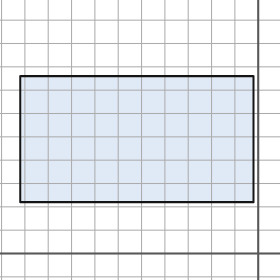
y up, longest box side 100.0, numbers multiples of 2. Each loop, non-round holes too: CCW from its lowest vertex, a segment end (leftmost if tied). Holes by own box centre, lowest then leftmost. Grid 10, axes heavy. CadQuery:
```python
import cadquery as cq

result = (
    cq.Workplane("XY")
    .moveTo(-102.0, 22.0)
    .lineTo(-2.0, 22.0)
    .lineTo(-2.0, 76.0)
    .lineTo(-102.0, 76.0)
    .close()
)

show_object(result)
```